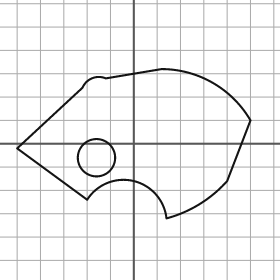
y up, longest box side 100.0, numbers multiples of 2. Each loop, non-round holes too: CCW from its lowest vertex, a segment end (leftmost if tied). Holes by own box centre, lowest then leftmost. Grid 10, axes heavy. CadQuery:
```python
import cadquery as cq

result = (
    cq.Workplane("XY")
    .moveTo(14.0, -32.0)
    .threePointArc((28.0, -26.0), (40.0, -16.0))
    .lineTo(50.0, 10.0)
    .threePointArc((34.0, 26.0), (12.0, 32.0))
    .lineTo(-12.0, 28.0)
    .threePointArc((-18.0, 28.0), (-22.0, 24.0))
    .lineTo(-50.0, -2.0)
    .lineTo(-20.0, -24.0)
    .threePointArc((0.0, -16.0), (14.0, -32.0))
    .close()
    .moveTo(-16.0, -6.0)
    .circle(8.0)
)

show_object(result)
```